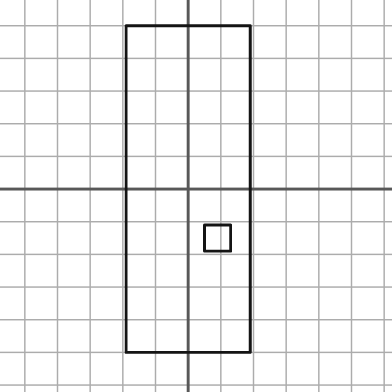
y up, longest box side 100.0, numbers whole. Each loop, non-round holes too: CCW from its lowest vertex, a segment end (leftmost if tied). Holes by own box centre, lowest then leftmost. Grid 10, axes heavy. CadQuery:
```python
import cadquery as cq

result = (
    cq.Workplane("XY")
    .moveTo(-19.0, -50.0)
    .lineTo(19.0, -50.0)
    .lineTo(19.0, 50.0)
    .lineTo(-19.0, 50.0)
    .close()
    .moveTo(5.0, -19.0)
    .lineTo(13.0, -19.0)
    .lineTo(13.0, -11.0)
    .lineTo(5.0, -11.0)
    .close()
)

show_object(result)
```